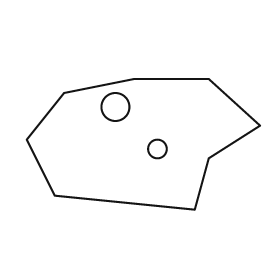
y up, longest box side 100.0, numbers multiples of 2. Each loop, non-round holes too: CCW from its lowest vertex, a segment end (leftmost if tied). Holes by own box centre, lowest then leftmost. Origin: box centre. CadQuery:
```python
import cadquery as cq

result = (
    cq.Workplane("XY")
    .moveTo(22.0, -28.0)
    .lineTo(28.0, -6.0)
    .lineTo(50.0, 8.0)
    .lineTo(28.0, 28.0)
    .lineTo(-4.0, 28.0)
    .lineTo(-34.0, 22.0)
    .lineTo(-50.0, 2.0)
    .lineTo(-38.0, -22.0)
    .close()
    .moveTo(6.0, -2.0)
    .circle(4.0)
    .moveTo(-12.0, 16.0)
    .circle(6.0)
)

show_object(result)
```